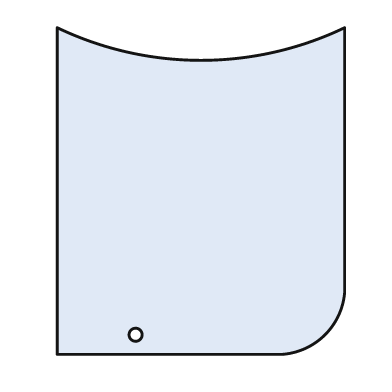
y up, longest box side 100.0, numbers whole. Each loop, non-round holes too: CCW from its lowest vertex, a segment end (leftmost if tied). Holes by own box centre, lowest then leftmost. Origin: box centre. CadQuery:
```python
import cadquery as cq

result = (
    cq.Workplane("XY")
    .moveTo(-44.0, -50.0)
    .lineTo(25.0, -50.0)
    .threePointArc((38.0, -44.0), (44.0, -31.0))
    .lineTo(44.0, 50.0)
    .threePointArc((0.0, 40.0), (-44.0, 50.0))
    .close()
    .moveTo(-20.0, -44.0)
    .circle(2.0)
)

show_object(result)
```